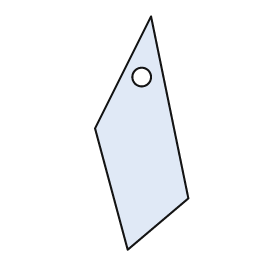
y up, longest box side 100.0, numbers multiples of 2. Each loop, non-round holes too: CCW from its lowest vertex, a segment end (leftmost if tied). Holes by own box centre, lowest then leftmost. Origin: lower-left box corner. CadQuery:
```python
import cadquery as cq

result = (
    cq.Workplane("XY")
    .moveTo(14.0, 0.0)
    .lineTo(40.0, 22.0)
    .lineTo(24.0, 100.0)
    .lineTo(0.0, 52.0)
    .close()
    .moveTo(20.0, 74.0)
    .circle(4.0)
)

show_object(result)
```